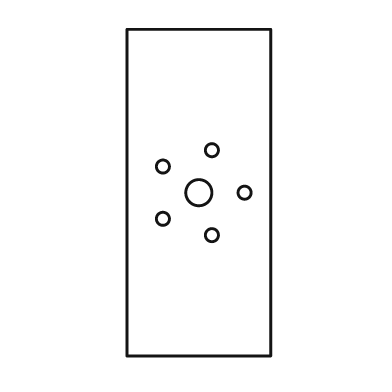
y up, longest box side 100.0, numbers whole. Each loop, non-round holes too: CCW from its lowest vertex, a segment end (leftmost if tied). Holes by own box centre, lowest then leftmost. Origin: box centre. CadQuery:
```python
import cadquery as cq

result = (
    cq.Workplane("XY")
    .moveTo(-22.0, -50.0)
    .lineTo(22.0, -50.0)
    .lineTo(22.0, 50.0)
    .lineTo(-22.0, 50.0)
    .close()
    .moveTo(4.0, -13.0)
    .circle(2.0)
    .moveTo(-11.0, -8.0)
    .circle(2.0)
    .moveTo(0.0, 0.0)
    .circle(4.0)
    .moveTo(14.0, 0.0)
    .circle(2.0)
    .moveTo(-11.0, 8.0)
    .circle(2.0)
    .moveTo(4.0, 13.0)
    .circle(2.0)
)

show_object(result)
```